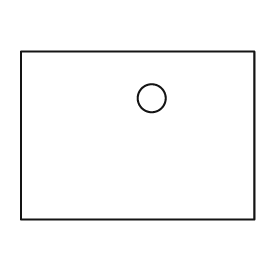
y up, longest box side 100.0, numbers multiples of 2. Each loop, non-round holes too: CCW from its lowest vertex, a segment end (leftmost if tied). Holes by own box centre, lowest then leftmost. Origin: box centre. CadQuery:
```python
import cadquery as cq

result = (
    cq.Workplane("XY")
    .moveTo(-50.0, -36.0)
    .lineTo(50.0, -36.0)
    .lineTo(50.0, 36.0)
    .lineTo(-50.0, 36.0)
    .close()
    .moveTo(6.0, 16.0)
    .circle(6.0)
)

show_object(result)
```